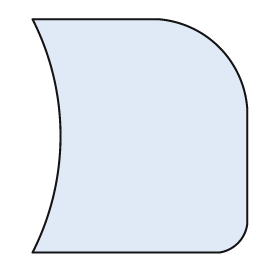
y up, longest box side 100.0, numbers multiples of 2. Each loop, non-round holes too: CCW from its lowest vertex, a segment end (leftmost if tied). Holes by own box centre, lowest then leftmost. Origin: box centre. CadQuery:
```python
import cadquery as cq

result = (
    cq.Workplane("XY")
    .moveTo(-46.0, -50.0)
    .lineTo(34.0, -50.0)
    .threePointArc((42.0, -46.0), (46.0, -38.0))
    .lineTo(46.0, 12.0)
    .threePointArc((34.0, 38.0), (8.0, 50.0))
    .lineTo(-46.0, 50.0)
    .threePointArc((-34.0, 0.0), (-46.0, -50.0))
    .close()
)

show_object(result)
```